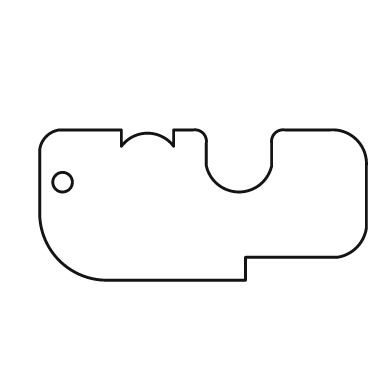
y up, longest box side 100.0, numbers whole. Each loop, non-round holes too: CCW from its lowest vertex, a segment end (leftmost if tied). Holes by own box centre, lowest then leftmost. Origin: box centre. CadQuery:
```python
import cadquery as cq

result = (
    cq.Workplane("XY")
    .moveTo(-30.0, -23.0)
    .lineTo(13.0, -23.0)
    .lineTo(13.0, -16.0)
    .lineTo(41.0, -16.0)
    .threePointArc((47.0, -13.0), (50.0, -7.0))
    .lineTo(50.0, 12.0)
    .threePointArc((47.0, 20.0), (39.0, 23.0))
    .lineTo(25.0, 23.0)
    .threePointArc((22.0, 22.0), (21.0, 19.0))
    .lineTo(21.0, 12.0)
    .threePointArc((11.0, 4.0), (1.0, 12.0))
    .lineTo(1.0, 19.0)
    .threePointArc((0.0, 22.0), (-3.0, 23.0))
    .lineTo(-9.0, 23.0)
    .lineTo(-9.0, 18.0)
    .threePointArc((-17.0, 22.0), (-25.0, 18.0))
    .lineTo(-25.0, 23.0)
    .lineTo(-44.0, 23.0)
    .threePointArc((-48.0, 21.0), (-50.0, 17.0))
    .lineTo(-50.0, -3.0)
    .threePointArc((-44.0, -17.0), (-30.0, -23.0))
    .close()
    .moveTo(-43.0, 7.0)
    .circle(3.0)
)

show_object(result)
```